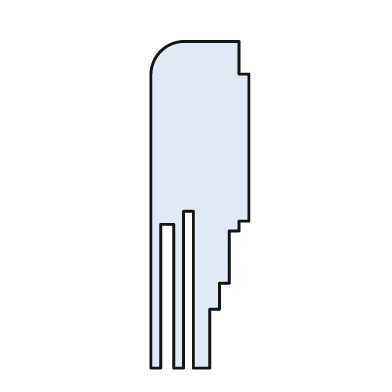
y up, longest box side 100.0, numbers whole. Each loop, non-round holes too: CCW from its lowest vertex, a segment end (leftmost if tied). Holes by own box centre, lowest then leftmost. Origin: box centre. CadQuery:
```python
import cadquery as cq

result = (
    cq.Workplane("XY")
    .moveTo(-15.0, -50.0)
    .lineTo(-12.0, -50.0)
    .lineTo(-12.0, -6.0)
    .lineTo(-8.0, -6.0)
    .lineTo(-8.0, -50.0)
    .lineTo(-5.0, -50.0)
    .lineTo(-5.0, -2.0)
    .lineTo(-2.0, -2.0)
    .lineTo(-2.0, -50.0)
    .lineTo(3.0, -50.0)
    .lineTo(3.0, -32.0)
    .lineTo(6.0, -32.0)
    .lineTo(6.0, -24.0)
    .lineTo(9.0, -24.0)
    .lineTo(9.0, -8.0)
    .lineTo(12.0, -8.0)
    .lineTo(12.0, -5.0)
    .lineTo(15.0, -5.0)
    .lineTo(15.0, 40.0)
    .lineTo(12.0, 40.0)
    .lineTo(12.0, 50.0)
    .lineTo(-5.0, 50.0)
    .threePointArc((-12.0, 47.0), (-15.0, 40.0))
    .close()
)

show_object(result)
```